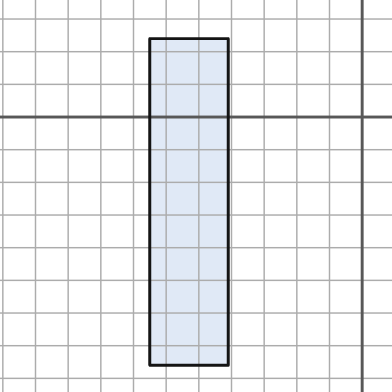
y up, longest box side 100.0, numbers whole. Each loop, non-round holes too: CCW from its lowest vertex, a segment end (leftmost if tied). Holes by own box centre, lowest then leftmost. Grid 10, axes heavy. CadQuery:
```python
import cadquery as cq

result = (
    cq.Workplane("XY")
    .moveTo(-65.0, -76.0)
    .lineTo(-41.0, -76.0)
    .lineTo(-41.0, 24.0)
    .lineTo(-65.0, 24.0)
    .close()
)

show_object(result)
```